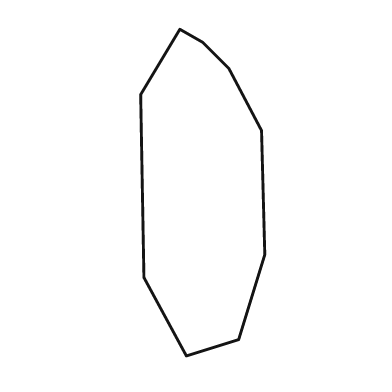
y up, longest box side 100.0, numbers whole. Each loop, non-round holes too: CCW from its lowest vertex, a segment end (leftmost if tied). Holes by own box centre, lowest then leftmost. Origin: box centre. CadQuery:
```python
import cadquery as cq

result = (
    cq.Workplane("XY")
    .moveTo(-5.0, -50.0)
    .lineTo(11.0, -45.0)
    .lineTo(19.0, -19.0)
    .lineTo(18.0, 19.0)
    .lineTo(8.0, 38.0)
    .lineTo(0.0, 46.0)
    .lineTo(-7.0, 50.0)
    .lineTo(-19.0, 30.0)
    .lineTo(-18.0, -26.0)
    .close()
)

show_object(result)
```